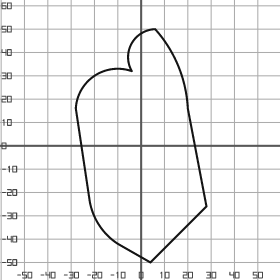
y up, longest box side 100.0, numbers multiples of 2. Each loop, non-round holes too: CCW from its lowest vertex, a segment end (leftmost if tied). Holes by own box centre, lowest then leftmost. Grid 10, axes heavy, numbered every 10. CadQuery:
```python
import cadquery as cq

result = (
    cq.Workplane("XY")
    .moveTo(4.0, -50.0)
    .lineTo(28.0, -26.0)
    .lineTo(20.0, 16.0)
    .threePointArc((16.0, 34.0), (6.0, 50.0))
    .threePointArc((-4.0, 44.0), (-4.0, 32.0))
    .threePointArc((-20.0, 30.0), (-28.0, 16.0))
    .lineTo(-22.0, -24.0)
    .threePointArc((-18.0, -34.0), (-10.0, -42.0))
    .close()
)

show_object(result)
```